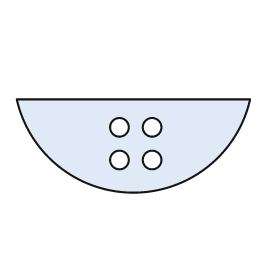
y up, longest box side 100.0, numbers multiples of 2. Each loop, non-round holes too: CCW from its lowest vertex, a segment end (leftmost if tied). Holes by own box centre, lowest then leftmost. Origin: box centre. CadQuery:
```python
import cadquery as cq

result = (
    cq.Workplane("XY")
    .moveTo(-50.0, 20.0)
    .threePointArc((0.0, -20.0), (50.0, 20.0))
    .close()
    .moveTo(-6.0, -6.0)
    .circle(4.0)
    .moveTo(8.0, -6.0)
    .circle(4.0)
    .moveTo(-6.0, 8.0)
    .circle(4.0)
    .moveTo(8.0, 8.0)
    .circle(4.0)
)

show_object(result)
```